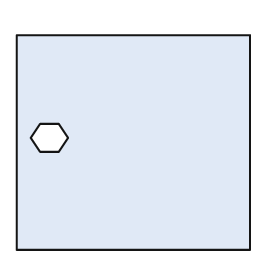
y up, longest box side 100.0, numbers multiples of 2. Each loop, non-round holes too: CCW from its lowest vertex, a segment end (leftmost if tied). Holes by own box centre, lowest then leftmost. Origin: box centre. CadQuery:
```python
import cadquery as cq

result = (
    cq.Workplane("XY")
    .moveTo(-50.0, -46.0)
    .lineTo(50.0, -46.0)
    .lineTo(50.0, 46.0)
    .lineTo(-50.0, 46.0)
    .close()
    .moveTo(-40.0, -4.0)
    .lineTo(-32.0, -4.0)
    .lineTo(-28.0, 2.0)
    .lineTo(-32.0, 8.0)
    .lineTo(-40.0, 8.0)
    .lineTo(-44.0, 2.0)
    .close()
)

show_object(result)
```